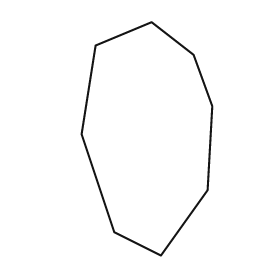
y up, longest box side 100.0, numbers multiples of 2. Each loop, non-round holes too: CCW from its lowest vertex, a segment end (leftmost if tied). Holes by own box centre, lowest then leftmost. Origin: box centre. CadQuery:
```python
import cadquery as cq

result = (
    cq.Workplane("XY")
    .moveTo(6.0, -50.0)
    .lineTo(26.0, -22.0)
    .lineTo(28.0, 14.0)
    .lineTo(20.0, 36.0)
    .lineTo(2.0, 50.0)
    .lineTo(-22.0, 40.0)
    .lineTo(-28.0, 2.0)
    .lineTo(-14.0, -40.0)
    .close()
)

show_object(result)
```